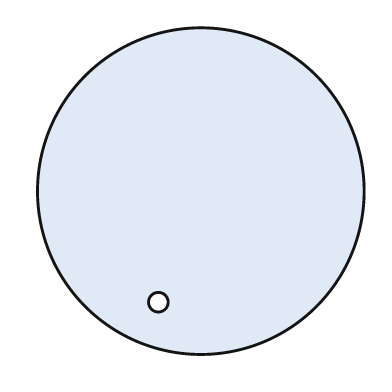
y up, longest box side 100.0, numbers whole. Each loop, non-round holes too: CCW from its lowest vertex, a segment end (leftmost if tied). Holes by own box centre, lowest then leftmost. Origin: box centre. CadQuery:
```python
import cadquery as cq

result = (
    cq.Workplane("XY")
    .moveTo(0.0, 0.0)
    .circle(50.0)
    .moveTo(-13.0, -34.0)
    .circle(3.0)
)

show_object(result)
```